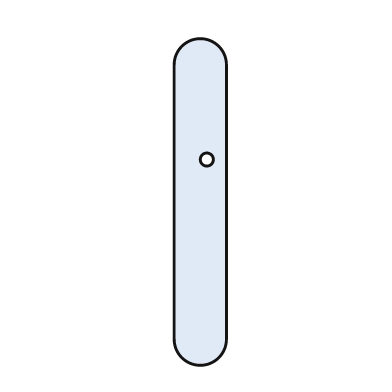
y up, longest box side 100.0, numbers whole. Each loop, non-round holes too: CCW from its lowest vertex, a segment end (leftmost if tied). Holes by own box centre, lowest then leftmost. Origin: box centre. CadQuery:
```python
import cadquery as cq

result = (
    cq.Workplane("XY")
    .moveTo(-8.0, -42.0)
    .threePointArc((0.0, -50.0), (8.0, -42.0))
    .lineTo(8.0, 42.0)
    .threePointArc((0.0, 50.0), (-8.0, 42.0))
    .close()
    .moveTo(2.0, 13.0)
    .circle(2.0)
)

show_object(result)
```